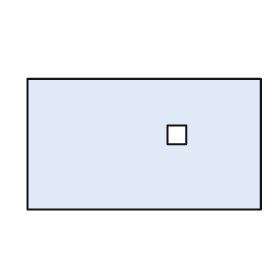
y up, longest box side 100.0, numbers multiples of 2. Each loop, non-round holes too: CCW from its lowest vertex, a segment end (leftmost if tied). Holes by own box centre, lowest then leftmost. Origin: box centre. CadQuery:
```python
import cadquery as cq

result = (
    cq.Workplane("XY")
    .moveTo(-50.0, -28.0)
    .lineTo(50.0, -28.0)
    .lineTo(50.0, 28.0)
    .lineTo(-50.0, 28.0)
    .close()
    .moveTo(10.0, 0.0)
    .lineTo(18.0, 0.0)
    .lineTo(18.0, 8.0)
    .lineTo(10.0, 8.0)
    .close()
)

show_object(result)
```